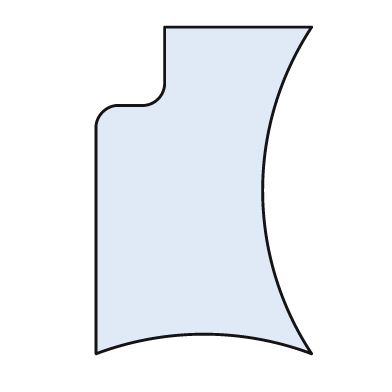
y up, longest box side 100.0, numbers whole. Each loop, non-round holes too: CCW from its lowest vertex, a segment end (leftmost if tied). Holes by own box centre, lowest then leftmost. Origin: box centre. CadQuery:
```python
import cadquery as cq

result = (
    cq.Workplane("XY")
    .moveTo(-33.0, -50.0)
    .threePointArc((0.0, -44.0), (33.0, -50.0))
    .threePointArc((18.0, 0.0), (33.0, 50.0))
    .lineTo(-12.0, 50.0)
    .lineTo(-12.0, 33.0)
    .threePointArc((-14.0, 28.0), (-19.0, 26.0))
    .lineTo(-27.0, 26.0)
    .threePointArc((-31.0, 24.0), (-33.0, 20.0))
    .close()
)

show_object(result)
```